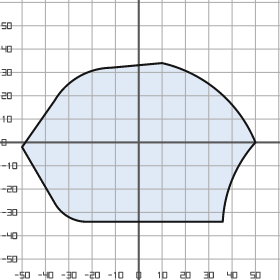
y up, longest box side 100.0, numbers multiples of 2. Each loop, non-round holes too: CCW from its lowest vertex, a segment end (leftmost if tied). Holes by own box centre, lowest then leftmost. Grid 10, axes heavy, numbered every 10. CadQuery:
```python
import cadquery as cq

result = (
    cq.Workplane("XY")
    .moveTo(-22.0, -34.0)
    .lineTo(36.0, -34.0)
    .threePointArc((40.0, -16.0), (50.0, 0.0))
    .threePointArc((34.0, 22.0), (10.0, 34.0))
    .lineTo(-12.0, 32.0)
    .threePointArc((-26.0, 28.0), (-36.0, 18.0))
    .lineTo(-50.0, -2.0)
    .lineTo(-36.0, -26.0)
    .threePointArc((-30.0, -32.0), (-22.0, -34.0))
    .close()
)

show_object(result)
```